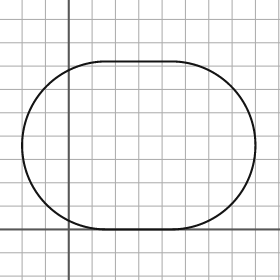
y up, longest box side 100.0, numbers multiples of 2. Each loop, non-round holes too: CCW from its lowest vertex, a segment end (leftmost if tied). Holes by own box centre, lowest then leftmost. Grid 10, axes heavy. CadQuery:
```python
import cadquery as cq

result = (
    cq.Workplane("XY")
    .moveTo(16.0, 0.0)
    .lineTo(44.0, 0.0)
    .threePointArc((80.0, 36.0), (44.0, 72.0))
    .lineTo(16.0, 72.0)
    .threePointArc((-20.0, 36.0), (16.0, 0.0))
    .close()
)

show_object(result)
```